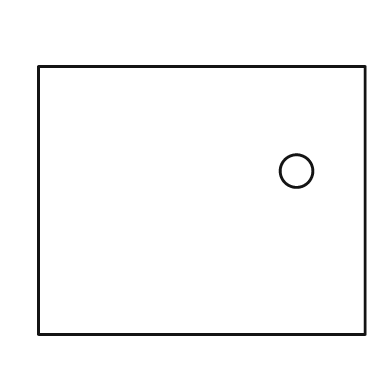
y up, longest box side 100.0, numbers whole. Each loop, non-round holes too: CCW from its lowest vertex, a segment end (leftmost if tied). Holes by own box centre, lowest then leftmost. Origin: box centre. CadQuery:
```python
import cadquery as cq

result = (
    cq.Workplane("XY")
    .moveTo(-50.0, -41.0)
    .lineTo(50.0, -41.0)
    .lineTo(50.0, 41.0)
    .lineTo(-50.0, 41.0)
    .close()
    .moveTo(29.0, 9.0)
    .circle(5.0)
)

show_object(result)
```